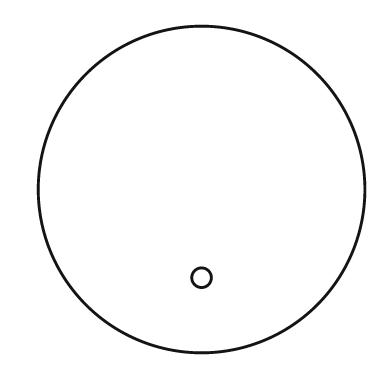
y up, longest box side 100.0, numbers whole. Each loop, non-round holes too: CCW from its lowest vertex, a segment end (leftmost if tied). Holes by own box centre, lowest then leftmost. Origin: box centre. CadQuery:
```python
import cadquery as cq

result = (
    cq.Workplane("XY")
    .moveTo(0.0, 0.0)
    .circle(50.0)
    .moveTo(0.0, -27.0)
    .circle(3.0)
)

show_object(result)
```